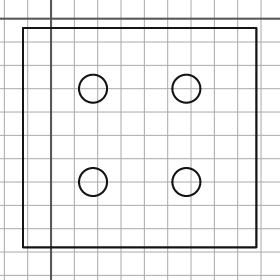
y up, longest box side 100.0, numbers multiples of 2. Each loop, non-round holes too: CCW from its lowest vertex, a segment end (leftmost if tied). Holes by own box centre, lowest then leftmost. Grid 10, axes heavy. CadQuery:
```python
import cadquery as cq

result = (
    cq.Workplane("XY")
    .moveTo(-12.0, -98.0)
    .lineTo(88.0, -98.0)
    .lineTo(88.0, -4.0)
    .lineTo(-12.0, -4.0)
    .close()
    .moveTo(18.0, -70.0)
    .circle(6.0)
    .moveTo(58.0, -70.0)
    .circle(6.0)
    .moveTo(18.0, -30.0)
    .circle(6.0)
    .moveTo(58.0, -30.0)
    .circle(6.0)
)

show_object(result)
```